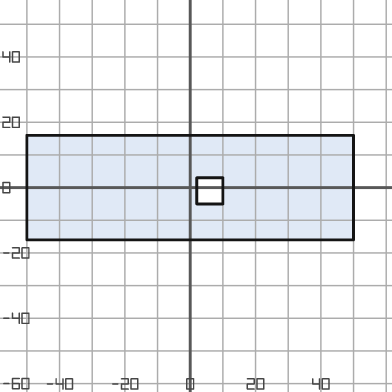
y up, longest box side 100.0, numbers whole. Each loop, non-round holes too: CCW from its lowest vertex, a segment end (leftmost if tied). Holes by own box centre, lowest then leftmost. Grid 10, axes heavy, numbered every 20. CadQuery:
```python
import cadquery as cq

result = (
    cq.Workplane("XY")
    .moveTo(-50.0, -16.0)
    .lineTo(50.0, -16.0)
    .lineTo(50.0, 16.0)
    .lineTo(-50.0, 16.0)
    .close()
    .moveTo(2.0, -5.0)
    .lineTo(10.0, -5.0)
    .lineTo(10.0, 3.0)
    .lineTo(2.0, 3.0)
    .close()
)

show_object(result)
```